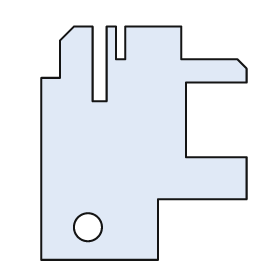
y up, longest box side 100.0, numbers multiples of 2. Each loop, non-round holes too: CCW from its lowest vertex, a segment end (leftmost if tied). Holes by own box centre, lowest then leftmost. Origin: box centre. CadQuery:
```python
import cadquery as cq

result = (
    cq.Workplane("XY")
    .moveTo(-44.0, -50.0)
    .lineTo(6.0, -50.0)
    .lineTo(6.0, -24.0)
    .lineTo(44.0, -24.0)
    .lineTo(44.0, -6.0)
    .lineTo(18.0, -6.0)
    .lineTo(18.0, 26.0)
    .lineTo(44.0, 26.0)
    .lineTo(44.0, 32.0)
    .lineTo(40.0, 36.0)
    .lineTo(16.0, 36.0)
    .lineTo(16.0, 50.0)
    .lineTo(-8.0, 50.0)
    .lineTo(-8.0, 36.0)
    .lineTo(-12.0, 36.0)
    .lineTo(-12.0, 50.0)
    .lineTo(-16.0, 50.0)
    .lineTo(-16.0, 18.0)
    .lineTo(-22.0, 18.0)
    .lineTo(-22.0, 50.0)
    .lineTo(-30.0, 50.0)
    .lineTo(-36.0, 44.0)
    .lineTo(-36.0, 28.0)
    .lineTo(-44.0, 28.0)
    .close()
    .moveTo(-24.0, -36.0)
    .circle(6.0)
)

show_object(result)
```